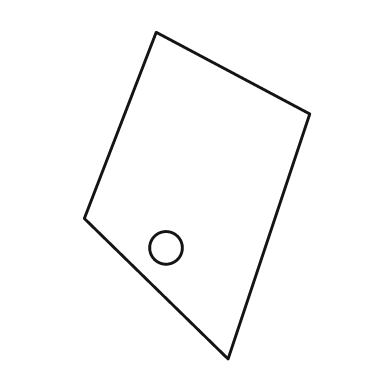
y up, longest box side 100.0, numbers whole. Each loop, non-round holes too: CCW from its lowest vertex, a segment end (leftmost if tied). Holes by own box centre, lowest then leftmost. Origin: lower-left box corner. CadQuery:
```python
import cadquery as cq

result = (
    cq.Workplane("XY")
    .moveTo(44.0, 0.0)
    .lineTo(69.0, 75.0)
    .lineTo(22.0, 100.0)
    .lineTo(0.0, 43.0)
    .close()
    .moveTo(25.0, 34.0)
    .circle(5.0)
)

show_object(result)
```